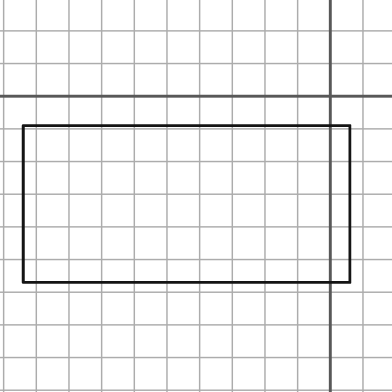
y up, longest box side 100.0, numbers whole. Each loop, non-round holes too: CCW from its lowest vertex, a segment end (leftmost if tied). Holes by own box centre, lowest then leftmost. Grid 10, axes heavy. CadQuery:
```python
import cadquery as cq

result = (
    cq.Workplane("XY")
    .moveTo(-94.0, -57.0)
    .lineTo(6.0, -57.0)
    .lineTo(6.0, -9.0)
    .lineTo(-94.0, -9.0)
    .close()
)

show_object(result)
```